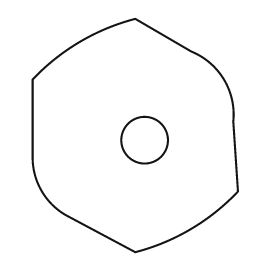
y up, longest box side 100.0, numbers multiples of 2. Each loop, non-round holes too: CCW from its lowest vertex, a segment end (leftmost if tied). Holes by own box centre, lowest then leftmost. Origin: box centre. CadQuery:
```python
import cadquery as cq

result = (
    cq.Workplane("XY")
    .moveTo(0.0, -50.0)
    .threePointArc((24.0, -40.0), (44.0, -24.0))
    .lineTo(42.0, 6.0)
    .threePointArc((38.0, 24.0), (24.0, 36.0))
    .lineTo(0.0, 50.0)
    .threePointArc((-24.0, 40.0), (-44.0, 24.0))
    .lineTo(-44.0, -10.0)
    .threePointArc((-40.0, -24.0), (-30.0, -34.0))
    .close()
    .moveTo(4.0, -2.0)
    .circle(10.0)
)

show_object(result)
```